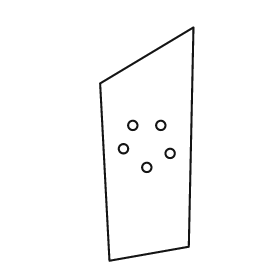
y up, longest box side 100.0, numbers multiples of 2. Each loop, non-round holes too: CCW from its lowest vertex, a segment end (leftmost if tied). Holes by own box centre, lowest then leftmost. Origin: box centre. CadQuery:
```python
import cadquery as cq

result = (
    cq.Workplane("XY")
    .moveTo(-16.0, -50.0)
    .lineTo(18.0, -44.0)
    .lineTo(20.0, 50.0)
    .lineTo(-20.0, 26.0)
    .close()
    .moveTo(0.0, -10.0)
    .circle(2.0)
    .moveTo(10.0, -4.0)
    .circle(2.0)
    .moveTo(-10.0, -2.0)
    .circle(2.0)
    .moveTo(-6.0, 8.0)
    .circle(2.0)
    .moveTo(6.0, 8.0)
    .circle(2.0)
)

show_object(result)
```